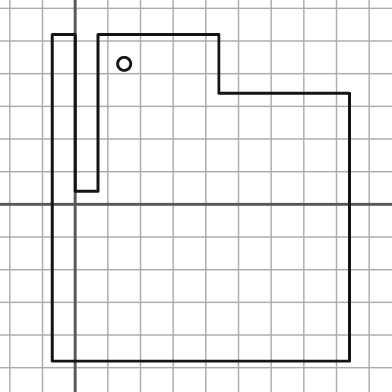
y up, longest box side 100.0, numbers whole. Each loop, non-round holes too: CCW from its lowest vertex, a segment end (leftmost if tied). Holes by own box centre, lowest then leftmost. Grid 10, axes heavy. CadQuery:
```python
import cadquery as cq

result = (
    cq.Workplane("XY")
    .moveTo(-7.0, -48.0)
    .lineTo(84.0, -48.0)
    .lineTo(84.0, 34.0)
    .lineTo(44.0, 34.0)
    .lineTo(44.0, 52.0)
    .lineTo(7.0, 52.0)
    .lineTo(7.0, 4.0)
    .lineTo(0.0, 4.0)
    .lineTo(0.0, 52.0)
    .lineTo(-7.0, 52.0)
    .close()
    .moveTo(15.0, 43.0)
    .circle(2.0)
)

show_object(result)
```